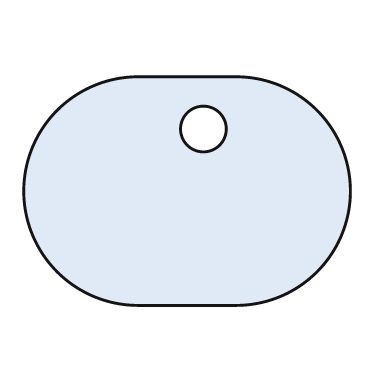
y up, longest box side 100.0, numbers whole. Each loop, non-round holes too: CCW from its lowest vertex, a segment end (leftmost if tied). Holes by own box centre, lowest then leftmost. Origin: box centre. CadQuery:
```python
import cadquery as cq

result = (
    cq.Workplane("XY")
    .moveTo(-15.0, -35.0)
    .lineTo(15.0, -35.0)
    .threePointArc((50.0, 0.0), (15.0, 35.0))
    .lineTo(-15.0, 35.0)
    .threePointArc((-50.0, 0.0), (-15.0, -35.0))
    .close()
    .moveTo(5.0, 19.0)
    .circle(7.0)
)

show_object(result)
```